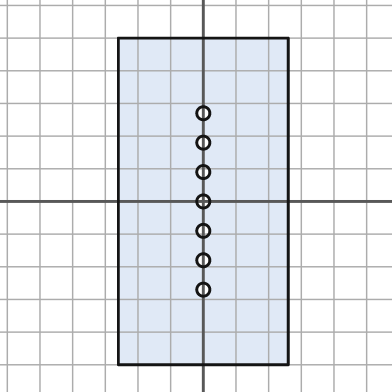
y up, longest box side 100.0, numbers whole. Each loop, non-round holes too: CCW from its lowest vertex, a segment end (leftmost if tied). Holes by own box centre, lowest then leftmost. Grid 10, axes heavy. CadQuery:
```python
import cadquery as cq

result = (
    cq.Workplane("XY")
    .moveTo(-26.0, -50.0)
    .lineTo(26.0, -50.0)
    .lineTo(26.0, 50.0)
    .lineTo(-26.0, 50.0)
    .close()
    .moveTo(0.0, -27.0)
    .circle(2.0)
    .moveTo(0.0, -18.0)
    .circle(2.0)
    .moveTo(0.0, -9.0)
    .circle(2.0)
    .moveTo(0.0, 0.0)
    .circle(2.0)
    .moveTo(0.0, 9.0)
    .circle(2.0)
    .moveTo(0.0, 18.0)
    .circle(2.0)
    .moveTo(0.0, 27.0)
    .circle(2.0)
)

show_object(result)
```